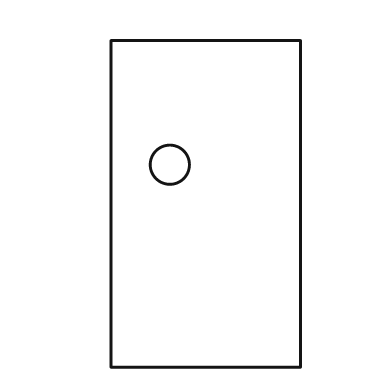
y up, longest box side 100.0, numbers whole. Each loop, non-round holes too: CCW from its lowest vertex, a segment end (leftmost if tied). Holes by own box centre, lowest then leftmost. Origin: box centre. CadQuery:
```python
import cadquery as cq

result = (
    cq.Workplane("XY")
    .moveTo(-29.0, -50.0)
    .lineTo(29.0, -50.0)
    .lineTo(29.0, 50.0)
    .lineTo(-29.0, 50.0)
    .close()
    .moveTo(-11.0, 12.0)
    .circle(6.0)
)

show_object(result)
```